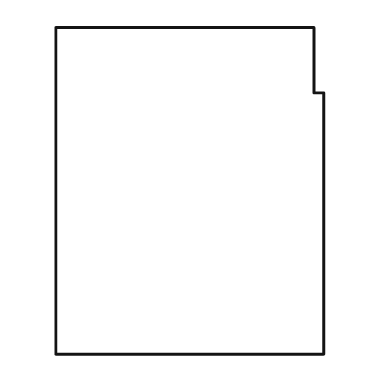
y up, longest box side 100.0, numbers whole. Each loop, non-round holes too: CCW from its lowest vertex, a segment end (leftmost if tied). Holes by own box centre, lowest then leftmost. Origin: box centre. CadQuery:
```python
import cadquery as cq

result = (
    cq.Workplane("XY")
    .moveTo(-41.0, -50.0)
    .lineTo(41.0, -50.0)
    .lineTo(41.0, 30.0)
    .lineTo(38.0, 30.0)
    .lineTo(38.0, 50.0)
    .lineTo(-41.0, 50.0)
    .close()
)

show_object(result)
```